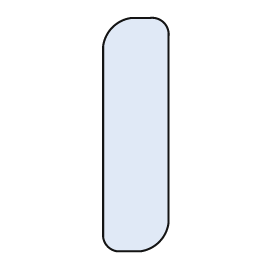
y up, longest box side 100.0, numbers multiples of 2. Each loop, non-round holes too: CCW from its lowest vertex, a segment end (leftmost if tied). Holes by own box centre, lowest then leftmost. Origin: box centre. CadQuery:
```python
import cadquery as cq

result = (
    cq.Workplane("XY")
    .moveTo(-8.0, -50.0)
    .lineTo(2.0, -50.0)
    .threePointArc((10.0, -46.0), (14.0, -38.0))
    .lineTo(14.0, 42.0)
    .threePointArc((12.0, 48.0), (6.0, 50.0))
    .lineTo(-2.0, 50.0)
    .threePointArc((-10.0, 46.0), (-14.0, 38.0))
    .lineTo(-14.0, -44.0)
    .threePointArc((-12.0, -48.0), (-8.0, -50.0))
    .close()
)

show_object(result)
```